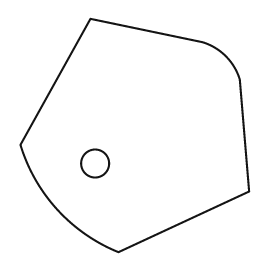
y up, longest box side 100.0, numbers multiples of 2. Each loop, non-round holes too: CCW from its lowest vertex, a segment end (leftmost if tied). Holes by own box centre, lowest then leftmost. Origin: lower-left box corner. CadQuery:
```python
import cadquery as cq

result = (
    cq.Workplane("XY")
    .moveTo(42.0, 0.0)
    .lineTo(98.0, 26.0)
    .lineTo(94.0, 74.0)
    .threePointArc((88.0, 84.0), (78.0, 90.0))
    .lineTo(30.0, 100.0)
    .lineTo(0.0, 46.0)
    .threePointArc((16.0, 18.0), (42.0, 0.0))
    .close()
    .moveTo(32.0, 38.0)
    .circle(6.0)
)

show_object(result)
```